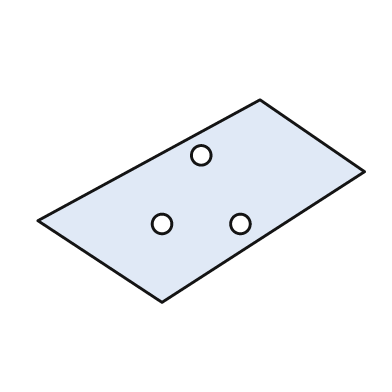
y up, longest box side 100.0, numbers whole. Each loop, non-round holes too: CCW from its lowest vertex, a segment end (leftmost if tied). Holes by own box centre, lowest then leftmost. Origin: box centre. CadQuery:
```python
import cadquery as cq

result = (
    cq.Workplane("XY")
    .moveTo(-12.0, -31.0)
    .lineTo(50.0, 9.0)
    .lineTo(18.0, 31.0)
    .lineTo(-50.0, -6.0)
    .close()
    .moveTo(-12.0, -7.0)
    .circle(3.0)
    .moveTo(12.0, -7.0)
    .circle(3.0)
    .moveTo(0.0, 14.0)
    .circle(3.0)
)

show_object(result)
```